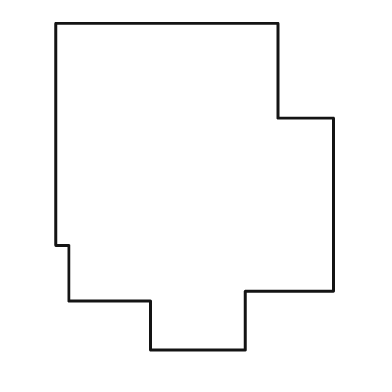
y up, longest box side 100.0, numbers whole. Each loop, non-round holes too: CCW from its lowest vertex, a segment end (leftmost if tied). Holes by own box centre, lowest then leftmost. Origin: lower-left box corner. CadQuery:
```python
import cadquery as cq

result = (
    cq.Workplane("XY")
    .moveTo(29.0, 0.0)
    .lineTo(58.0, 0.0)
    .lineTo(58.0, 18.0)
    .lineTo(85.0, 18.0)
    .lineTo(85.0, 71.0)
    .lineTo(68.0, 71.0)
    .lineTo(68.0, 100.0)
    .lineTo(0.0, 100.0)
    .lineTo(0.0, 32.0)
    .lineTo(4.0, 32.0)
    .lineTo(4.0, 15.0)
    .lineTo(29.0, 15.0)
    .close()
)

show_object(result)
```